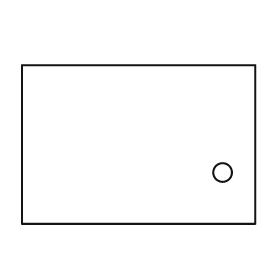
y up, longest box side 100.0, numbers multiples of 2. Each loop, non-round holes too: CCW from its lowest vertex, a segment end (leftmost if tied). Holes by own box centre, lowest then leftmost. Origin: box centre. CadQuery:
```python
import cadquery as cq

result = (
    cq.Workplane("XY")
    .moveTo(-50.0, -34.0)
    .lineTo(50.0, -34.0)
    .lineTo(50.0, 34.0)
    .lineTo(-50.0, 34.0)
    .close()
    .moveTo(36.0, -12.0)
    .circle(4.0)
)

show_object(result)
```